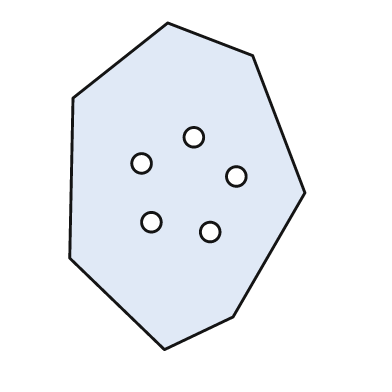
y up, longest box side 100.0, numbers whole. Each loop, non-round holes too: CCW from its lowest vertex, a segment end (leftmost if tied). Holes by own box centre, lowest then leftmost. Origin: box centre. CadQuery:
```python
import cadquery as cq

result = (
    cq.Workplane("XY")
    .moveTo(-7.0, -50.0)
    .lineTo(14.0, -40.0)
    .lineTo(36.0, -2.0)
    .lineTo(20.0, 40.0)
    .lineTo(-6.0, 50.0)
    .lineTo(-35.0, 27.0)
    .lineTo(-36.0, -22.0)
    .close()
    .moveTo(7.0, -14.0)
    .circle(3.0)
    .moveTo(-11.0, -11.0)
    .circle(3.0)
    .moveTo(15.0, 3.0)
    .circle(3.0)
    .moveTo(-14.0, 7.0)
    .circle(3.0)
    .moveTo(2.0, 15.0)
    .circle(3.0)
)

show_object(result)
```